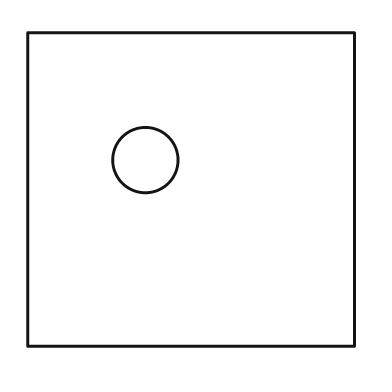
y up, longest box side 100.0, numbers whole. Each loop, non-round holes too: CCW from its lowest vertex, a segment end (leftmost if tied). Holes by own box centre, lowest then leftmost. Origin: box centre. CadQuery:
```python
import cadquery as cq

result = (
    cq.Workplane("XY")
    .moveTo(-50.0, -48.0)
    .lineTo(50.0, -48.0)
    .lineTo(50.0, 48.0)
    .lineTo(-50.0, 48.0)
    .close()
    .moveTo(-14.0, 9.0)
    .circle(10.0)
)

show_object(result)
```